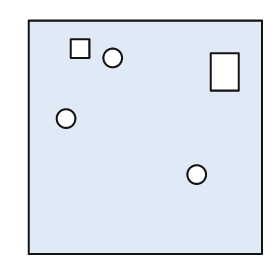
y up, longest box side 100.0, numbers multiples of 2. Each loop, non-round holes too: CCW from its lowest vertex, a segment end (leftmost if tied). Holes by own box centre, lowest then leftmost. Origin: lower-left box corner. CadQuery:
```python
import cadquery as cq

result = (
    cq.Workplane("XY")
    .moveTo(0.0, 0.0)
    .lineTo(100.0, 0.0)
    .lineTo(100.0, 100.0)
    .lineTo(0.0, 100.0)
    .close()
    .moveTo(72.0, 34.0)
    .circle(4.0)
    .moveTo(16.0, 58.0)
    .circle(4.0)
    .moveTo(78.0, 70.0)
    .lineTo(90.0, 70.0)
    .lineTo(90.0, 86.0)
    .lineTo(78.0, 86.0)
    .close()
    .moveTo(36.0, 84.0)
    .circle(4.0)
    .moveTo(18.0, 84.0)
    .lineTo(26.0, 84.0)
    .lineTo(26.0, 92.0)
    .lineTo(18.0, 92.0)
    .close()
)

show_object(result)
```